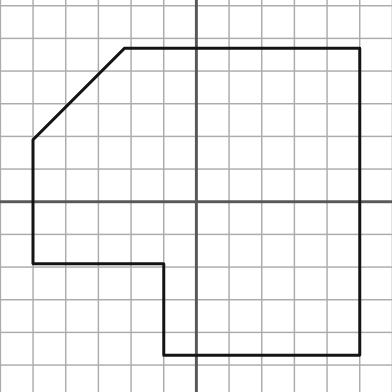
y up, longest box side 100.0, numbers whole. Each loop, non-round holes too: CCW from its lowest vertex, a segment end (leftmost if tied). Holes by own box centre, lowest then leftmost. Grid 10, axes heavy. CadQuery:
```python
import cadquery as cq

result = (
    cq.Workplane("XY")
    .moveTo(-10.0, -47.0)
    .lineTo(50.0, -47.0)
    .lineTo(50.0, 47.0)
    .lineTo(-22.0, 47.0)
    .lineTo(-50.0, 19.0)
    .lineTo(-50.0, -19.0)
    .lineTo(-10.0, -19.0)
    .close()
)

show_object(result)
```